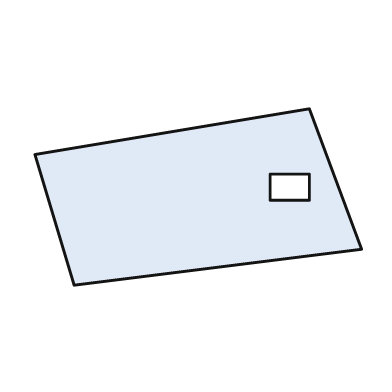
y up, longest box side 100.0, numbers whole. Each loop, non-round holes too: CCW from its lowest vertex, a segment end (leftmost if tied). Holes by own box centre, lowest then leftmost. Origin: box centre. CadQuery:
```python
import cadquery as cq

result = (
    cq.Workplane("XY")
    .moveTo(-38.0, -27.0)
    .lineTo(50.0, -16.0)
    .lineTo(34.0, 27.0)
    .lineTo(-50.0, 13.0)
    .close()
    .moveTo(22.0, -1.0)
    .lineTo(34.0, -1.0)
    .lineTo(34.0, 7.0)
    .lineTo(22.0, 7.0)
    .close()
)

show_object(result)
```